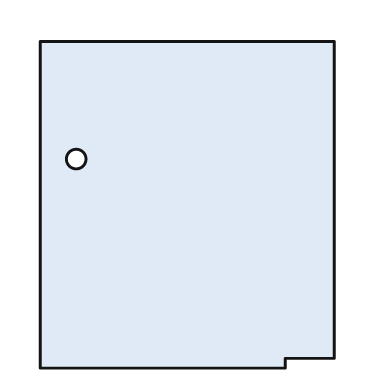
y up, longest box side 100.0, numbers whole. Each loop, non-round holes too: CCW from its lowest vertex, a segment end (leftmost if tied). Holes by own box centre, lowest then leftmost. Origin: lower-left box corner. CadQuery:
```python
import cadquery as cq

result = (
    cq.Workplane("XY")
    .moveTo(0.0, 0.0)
    .lineTo(75.0, 0.0)
    .lineTo(75.0, 3.0)
    .lineTo(90.0, 3.0)
    .lineTo(90.0, 100.0)
    .lineTo(0.0, 100.0)
    .close()
    .moveTo(11.0, 64.0)
    .circle(3.0)
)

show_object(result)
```